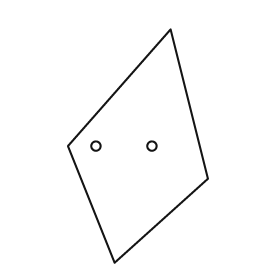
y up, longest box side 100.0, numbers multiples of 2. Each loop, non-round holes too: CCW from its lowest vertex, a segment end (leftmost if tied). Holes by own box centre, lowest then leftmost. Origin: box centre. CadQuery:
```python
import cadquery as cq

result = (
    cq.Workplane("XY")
    .moveTo(-10.0, -50.0)
    .lineTo(30.0, -14.0)
    .lineTo(14.0, 50.0)
    .lineTo(-30.0, 0.0)
    .close()
    .moveTo(-18.0, 0.0)
    .circle(2.0)
    .moveTo(6.0, 0.0)
    .circle(2.0)
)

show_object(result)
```